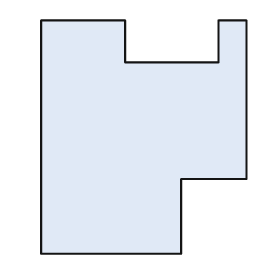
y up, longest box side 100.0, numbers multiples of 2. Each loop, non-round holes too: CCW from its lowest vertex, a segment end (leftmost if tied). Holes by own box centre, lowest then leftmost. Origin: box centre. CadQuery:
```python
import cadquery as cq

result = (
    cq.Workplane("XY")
    .moveTo(-44.0, -50.0)
    .lineTo(16.0, -50.0)
    .lineTo(16.0, -18.0)
    .lineTo(44.0, -18.0)
    .lineTo(44.0, 50.0)
    .lineTo(32.0, 50.0)
    .lineTo(32.0, 32.0)
    .lineTo(-8.0, 32.0)
    .lineTo(-8.0, 50.0)
    .lineTo(-44.0, 50.0)
    .close()
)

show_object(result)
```